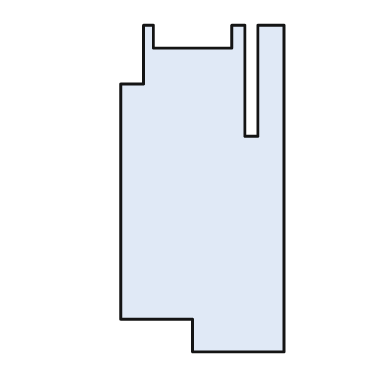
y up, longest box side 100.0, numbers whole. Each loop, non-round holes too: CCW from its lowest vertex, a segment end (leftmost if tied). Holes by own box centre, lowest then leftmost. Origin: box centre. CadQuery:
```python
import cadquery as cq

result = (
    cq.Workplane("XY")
    .moveTo(-3.0, -50.0)
    .lineTo(25.0, -50.0)
    .lineTo(25.0, 50.0)
    .lineTo(17.0, 50.0)
    .lineTo(17.0, 16.0)
    .lineTo(13.0, 16.0)
    .lineTo(13.0, 50.0)
    .lineTo(9.0, 50.0)
    .lineTo(9.0, 43.0)
    .lineTo(-15.0, 43.0)
    .lineTo(-15.0, 50.0)
    .lineTo(-18.0, 50.0)
    .lineTo(-18.0, 32.0)
    .lineTo(-25.0, 32.0)
    .lineTo(-25.0, -40.0)
    .lineTo(-3.0, -40.0)
    .close()
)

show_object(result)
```